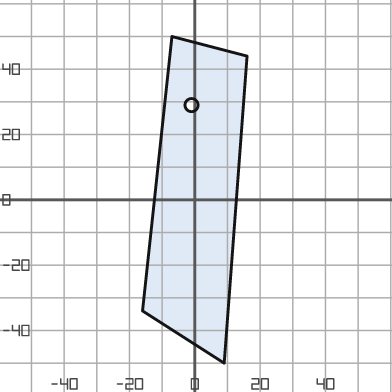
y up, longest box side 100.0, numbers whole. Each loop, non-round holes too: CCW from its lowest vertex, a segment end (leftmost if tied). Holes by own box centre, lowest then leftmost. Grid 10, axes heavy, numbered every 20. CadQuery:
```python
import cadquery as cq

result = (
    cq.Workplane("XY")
    .moveTo(9.0, -50.0)
    .lineTo(16.0, 44.0)
    .lineTo(-7.0, 50.0)
    .lineTo(-16.0, -34.0)
    .close()
    .moveTo(-1.0, 29.0)
    .circle(2.0)
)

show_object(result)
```